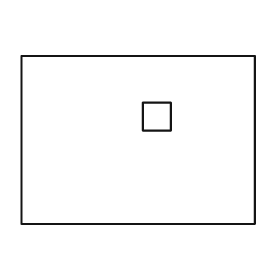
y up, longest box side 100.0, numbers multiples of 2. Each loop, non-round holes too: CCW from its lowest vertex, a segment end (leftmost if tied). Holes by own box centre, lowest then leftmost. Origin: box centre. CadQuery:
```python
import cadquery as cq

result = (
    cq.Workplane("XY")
    .moveTo(-50.0, -36.0)
    .lineTo(50.0, -36.0)
    .lineTo(50.0, 36.0)
    .lineTo(-50.0, 36.0)
    .close()
    .moveTo(2.0, 4.0)
    .lineTo(14.0, 4.0)
    .lineTo(14.0, 16.0)
    .lineTo(2.0, 16.0)
    .close()
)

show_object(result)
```